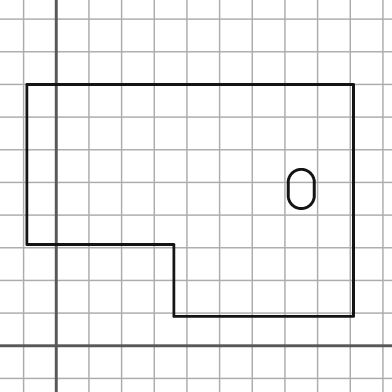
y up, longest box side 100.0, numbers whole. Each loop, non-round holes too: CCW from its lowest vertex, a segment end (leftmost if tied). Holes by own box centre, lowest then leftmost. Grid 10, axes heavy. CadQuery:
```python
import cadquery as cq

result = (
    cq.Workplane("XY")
    .moveTo(36.0, 9.0)
    .lineTo(91.0, 9.0)
    .lineTo(91.0, 80.0)
    .lineTo(-9.0, 80.0)
    .lineTo(-9.0, 31.0)
    .lineTo(36.0, 31.0)
    .close()
    .moveTo(71.0, 46.0)
    .threePointArc((75.0, 42.0), (79.0, 46.0))
    .lineTo(79.0, 50.0)
    .threePointArc((75.0, 54.0), (71.0, 50.0))
    .close()
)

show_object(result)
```